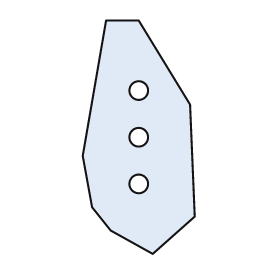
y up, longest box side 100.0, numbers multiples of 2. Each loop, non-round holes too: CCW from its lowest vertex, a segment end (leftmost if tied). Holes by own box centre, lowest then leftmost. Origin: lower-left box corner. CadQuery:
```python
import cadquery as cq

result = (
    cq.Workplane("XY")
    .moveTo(30.0, 0.0)
    .lineTo(48.0, 16.0)
    .lineTo(46.0, 64.0)
    .lineTo(24.0, 100.0)
    .lineTo(10.0, 100.0)
    .lineTo(0.0, 42.0)
    .lineTo(4.0, 20.0)
    .lineTo(12.0, 10.0)
    .close()
    .moveTo(24.0, 30.0)
    .circle(4.0)
    .moveTo(24.0, 50.0)
    .circle(4.0)
    .moveTo(24.0, 70.0)
    .circle(4.0)
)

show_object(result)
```